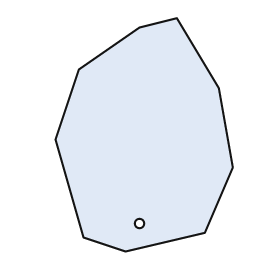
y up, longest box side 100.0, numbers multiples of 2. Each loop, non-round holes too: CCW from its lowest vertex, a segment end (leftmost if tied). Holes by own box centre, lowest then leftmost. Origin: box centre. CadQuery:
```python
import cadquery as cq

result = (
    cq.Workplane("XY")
    .moveTo(-8.0, -50.0)
    .lineTo(26.0, -42.0)
    .lineTo(38.0, -14.0)
    .lineTo(32.0, 20.0)
    .lineTo(14.0, 50.0)
    .lineTo(-2.0, 46.0)
    .lineTo(-28.0, 28.0)
    .lineTo(-38.0, -2.0)
    .lineTo(-26.0, -44.0)
    .close()
    .moveTo(-2.0, -38.0)
    .circle(2.0)
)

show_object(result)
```